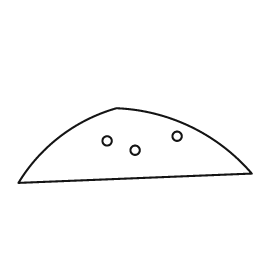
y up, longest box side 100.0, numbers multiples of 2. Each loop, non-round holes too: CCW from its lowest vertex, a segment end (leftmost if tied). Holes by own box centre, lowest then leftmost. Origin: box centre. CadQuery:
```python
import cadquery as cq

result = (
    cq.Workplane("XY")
    .moveTo(-50.0, -16.0)
    .lineTo(50.0, -12.0)
    .threePointArc((24.0, 8.0), (-8.0, 16.0))
    .threePointArc((-32.0, 4.0), (-50.0, -16.0))
    .close()
    .moveTo(0.0, -2.0)
    .circle(2.0)
    .moveTo(-12.0, 2.0)
    .circle(2.0)
    .moveTo(18.0, 4.0)
    .circle(2.0)
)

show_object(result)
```